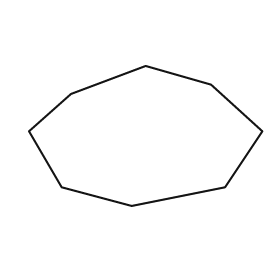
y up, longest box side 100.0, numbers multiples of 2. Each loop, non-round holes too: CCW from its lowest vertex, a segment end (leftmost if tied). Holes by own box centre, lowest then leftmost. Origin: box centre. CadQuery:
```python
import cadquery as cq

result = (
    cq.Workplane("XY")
    .moveTo(-6.0, -30.0)
    .lineTo(34.0, -22.0)
    .lineTo(50.0, 2.0)
    .lineTo(28.0, 22.0)
    .lineTo(0.0, 30.0)
    .lineTo(-32.0, 18.0)
    .lineTo(-50.0, 2.0)
    .lineTo(-36.0, -22.0)
    .close()
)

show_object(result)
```